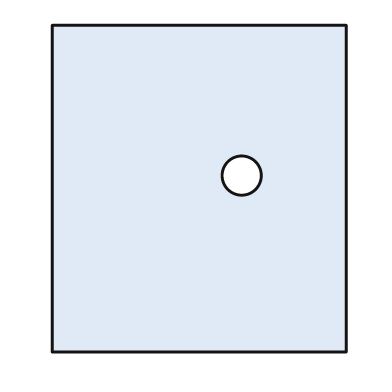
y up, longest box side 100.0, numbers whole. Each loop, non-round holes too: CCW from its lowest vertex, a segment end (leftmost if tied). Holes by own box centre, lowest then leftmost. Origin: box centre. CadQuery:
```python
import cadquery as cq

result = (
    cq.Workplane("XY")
    .moveTo(-45.0, -50.0)
    .lineTo(45.0, -50.0)
    .lineTo(45.0, 50.0)
    .lineTo(-45.0, 50.0)
    .close()
    .moveTo(13.0, 4.0)
    .circle(6.0)
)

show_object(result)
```